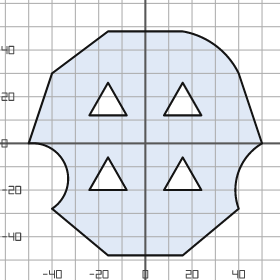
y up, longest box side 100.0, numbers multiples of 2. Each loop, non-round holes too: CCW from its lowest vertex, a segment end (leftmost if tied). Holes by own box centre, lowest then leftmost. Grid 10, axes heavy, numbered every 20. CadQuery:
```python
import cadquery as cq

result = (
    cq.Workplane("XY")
    .moveTo(-16.0, -48.0)
    .lineTo(16.0, -48.0)
    .lineTo(40.0, -28.0)
    .threePointArc((40.0, -12.0), (50.0, 0.0))
    .lineTo(40.0, 30.0)
    .threePointArc((30.0, 42.0), (16.0, 48.0))
    .lineTo(-16.0, 48.0)
    .lineTo(-40.0, 30.0)
    .lineTo(-50.0, 0.0)
    .threePointArc((-34.0, -10.0), (-40.0, -28.0))
    .close()
    .moveTo(-24.0, -20.0)
    .lineTo(-8.0, -20.0)
    .lineTo(-16.0, -6.0)
    .close()
    .moveTo(8.0, -20.0)
    .lineTo(24.0, -20.0)
    .lineTo(16.0, -6.0)
    .close()
    .moveTo(-24.0, 12.0)
    .lineTo(-8.0, 12.0)
    .lineTo(-16.0, 26.0)
    .close()
    .moveTo(8.0, 12.0)
    .lineTo(24.0, 12.0)
    .lineTo(16.0, 26.0)
    .close()
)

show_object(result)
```